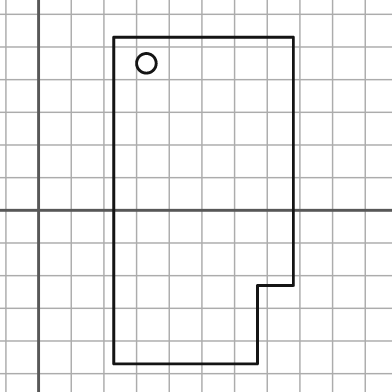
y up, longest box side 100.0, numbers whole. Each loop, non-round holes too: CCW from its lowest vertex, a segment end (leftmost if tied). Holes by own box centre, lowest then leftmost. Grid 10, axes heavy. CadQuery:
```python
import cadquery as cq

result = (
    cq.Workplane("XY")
    .moveTo(23.0, -47.0)
    .lineTo(67.0, -47.0)
    .lineTo(67.0, -23.0)
    .lineTo(78.0, -23.0)
    .lineTo(78.0, 53.0)
    .lineTo(23.0, 53.0)
    .close()
    .moveTo(33.0, 45.0)
    .circle(3.0)
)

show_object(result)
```